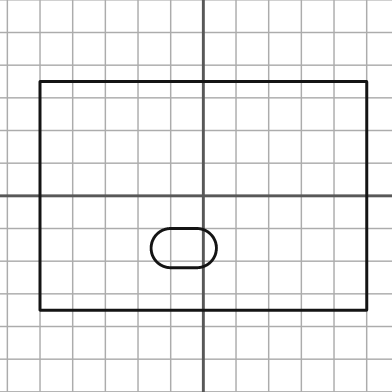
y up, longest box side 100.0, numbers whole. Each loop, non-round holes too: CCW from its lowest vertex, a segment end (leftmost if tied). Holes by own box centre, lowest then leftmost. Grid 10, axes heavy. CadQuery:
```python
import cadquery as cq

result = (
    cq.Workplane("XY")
    .moveTo(-50.0, -35.0)
    .lineTo(50.0, -35.0)
    .lineTo(50.0, 35.0)
    .lineTo(-50.0, 35.0)
    .close()
    .moveTo(-10.0, -22.0)
    .lineTo(-2.0, -22.0)
    .threePointArc((4.0, -16.0), (-2.0, -10.0))
    .lineTo(-10.0, -10.0)
    .threePointArc((-16.0, -16.0), (-10.0, -22.0))
    .close()
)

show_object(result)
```